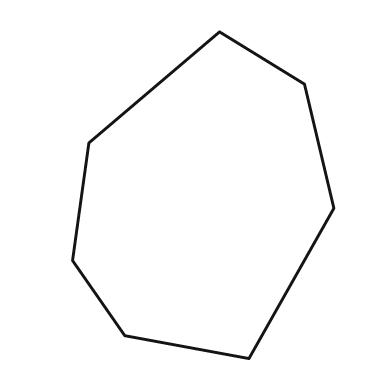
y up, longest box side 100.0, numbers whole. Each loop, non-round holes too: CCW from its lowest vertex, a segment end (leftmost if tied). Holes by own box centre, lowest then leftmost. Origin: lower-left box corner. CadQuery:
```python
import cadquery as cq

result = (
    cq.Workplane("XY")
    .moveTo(54.0, 0.0)
    .lineTo(80.0, 46.0)
    .lineTo(71.0, 84.0)
    .lineTo(45.0, 100.0)
    .lineTo(5.0, 66.0)
    .lineTo(0.0, 30.0)
    .lineTo(16.0, 7.0)
    .close()
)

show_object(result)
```